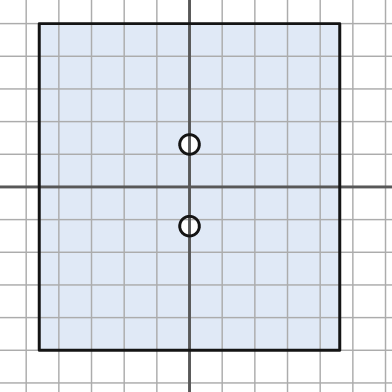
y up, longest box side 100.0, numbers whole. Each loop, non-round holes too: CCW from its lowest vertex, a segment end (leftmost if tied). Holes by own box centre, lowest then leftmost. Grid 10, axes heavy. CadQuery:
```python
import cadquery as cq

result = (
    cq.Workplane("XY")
    .moveTo(-46.0, -50.0)
    .lineTo(46.0, -50.0)
    .lineTo(46.0, 50.0)
    .lineTo(-46.0, 50.0)
    .close()
    .moveTo(0.0, -12.0)
    .circle(3.0)
    .moveTo(0.0, 13.0)
    .circle(3.0)
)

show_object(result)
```